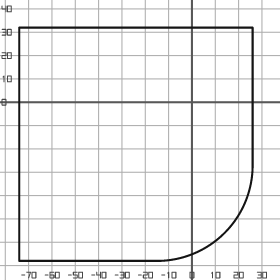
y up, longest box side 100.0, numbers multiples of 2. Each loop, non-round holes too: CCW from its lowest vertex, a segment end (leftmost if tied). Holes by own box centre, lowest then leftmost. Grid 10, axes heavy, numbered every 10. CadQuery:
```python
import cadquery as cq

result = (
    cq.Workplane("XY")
    .moveTo(-74.0, -68.0)
    .lineTo(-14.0, -68.0)
    .threePointArc((14.0, -56.0), (26.0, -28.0))
    .lineTo(26.0, 32.0)
    .lineTo(-74.0, 32.0)
    .close()
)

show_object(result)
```